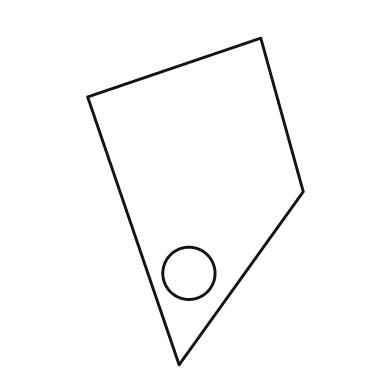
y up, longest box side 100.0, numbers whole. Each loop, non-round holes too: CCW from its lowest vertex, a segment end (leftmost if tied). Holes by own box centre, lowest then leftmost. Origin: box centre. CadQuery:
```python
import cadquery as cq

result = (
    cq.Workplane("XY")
    .moveTo(-5.0, -50.0)
    .lineTo(33.0, 3.0)
    .lineTo(20.0, 50.0)
    .lineTo(-33.0, 32.0)
    .close()
    .moveTo(-2.0, -22.0)
    .circle(8.0)
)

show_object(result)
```